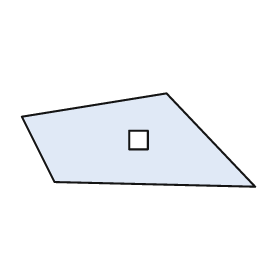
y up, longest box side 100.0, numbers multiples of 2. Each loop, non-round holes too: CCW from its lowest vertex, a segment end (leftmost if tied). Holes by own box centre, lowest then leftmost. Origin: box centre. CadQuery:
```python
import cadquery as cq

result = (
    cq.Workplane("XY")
    .moveTo(50.0, -20.0)
    .lineTo(12.0, 20.0)
    .lineTo(-50.0, 10.0)
    .lineTo(-36.0, -18.0)
    .close()
    .moveTo(-4.0, -4.0)
    .lineTo(4.0, -4.0)
    .lineTo(4.0, 4.0)
    .lineTo(-4.0, 4.0)
    .close()
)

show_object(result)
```